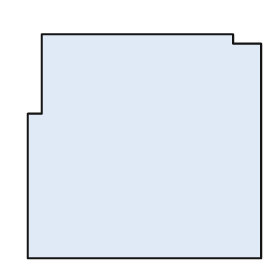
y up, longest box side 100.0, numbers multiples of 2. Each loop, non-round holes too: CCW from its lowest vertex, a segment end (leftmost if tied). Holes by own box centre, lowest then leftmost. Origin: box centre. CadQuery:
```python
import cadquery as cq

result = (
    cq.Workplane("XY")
    .moveTo(-50.0, -48.0)
    .lineTo(50.0, -48.0)
    .lineTo(50.0, 44.0)
    .lineTo(38.0, 44.0)
    .lineTo(38.0, 48.0)
    .lineTo(-44.0, 48.0)
    .lineTo(-44.0, 14.0)
    .lineTo(-50.0, 14.0)
    .close()
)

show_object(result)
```